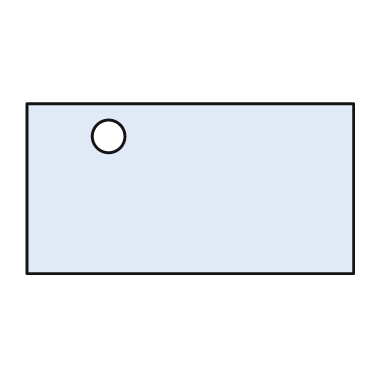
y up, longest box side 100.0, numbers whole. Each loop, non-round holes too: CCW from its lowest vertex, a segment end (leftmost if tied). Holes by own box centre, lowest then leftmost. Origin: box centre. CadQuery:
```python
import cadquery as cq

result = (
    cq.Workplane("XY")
    .moveTo(-50.0, -26.0)
    .lineTo(50.0, -26.0)
    .lineTo(50.0, 26.0)
    .lineTo(-50.0, 26.0)
    .close()
    .moveTo(-25.0, 16.0)
    .circle(5.0)
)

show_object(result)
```